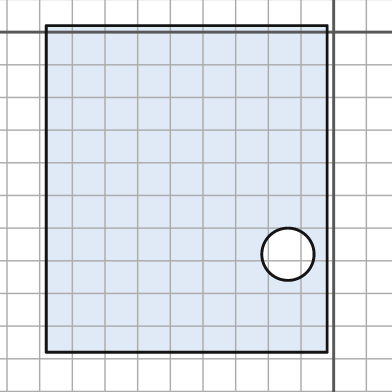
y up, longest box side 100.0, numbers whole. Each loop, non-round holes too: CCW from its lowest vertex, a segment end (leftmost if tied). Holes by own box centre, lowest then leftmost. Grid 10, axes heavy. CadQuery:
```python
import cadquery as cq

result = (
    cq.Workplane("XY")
    .moveTo(-88.0, -98.0)
    .lineTo(-2.0, -98.0)
    .lineTo(-2.0, 2.0)
    .lineTo(-88.0, 2.0)
    .close()
    .moveTo(-14.0, -68.0)
    .circle(8.0)
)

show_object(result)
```